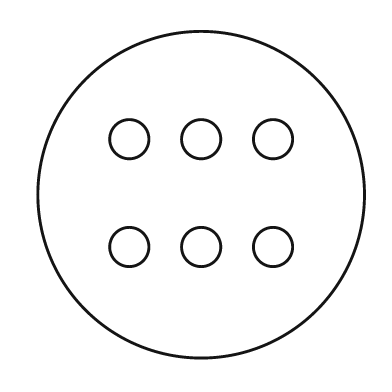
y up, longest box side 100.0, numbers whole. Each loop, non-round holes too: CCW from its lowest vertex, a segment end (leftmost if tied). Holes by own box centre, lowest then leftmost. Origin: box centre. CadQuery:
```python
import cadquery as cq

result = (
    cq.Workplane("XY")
    .moveTo(0.0, 0.0)
    .circle(50.0)
    .moveTo(-22.0, -16.0)
    .circle(6.0)
    .moveTo(0.0, -16.0)
    .circle(6.0)
    .moveTo(22.0, -16.0)
    .circle(6.0)
    .moveTo(-22.0, 17.0)
    .circle(6.0)
    .moveTo(0.0, 17.0)
    .circle(6.0)
    .moveTo(22.0, 17.0)
    .circle(6.0)
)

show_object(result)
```